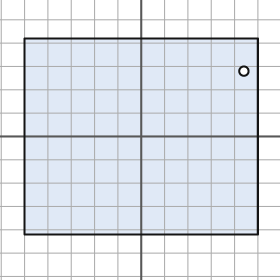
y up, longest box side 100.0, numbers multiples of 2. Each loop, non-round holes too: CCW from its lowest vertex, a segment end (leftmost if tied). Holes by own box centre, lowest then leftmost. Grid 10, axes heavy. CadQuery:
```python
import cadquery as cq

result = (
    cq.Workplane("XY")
    .moveTo(-50.0, -42.0)
    .lineTo(50.0, -42.0)
    .lineTo(50.0, 42.0)
    .lineTo(-50.0, 42.0)
    .close()
    .moveTo(44.0, 28.0)
    .circle(2.0)
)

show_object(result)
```